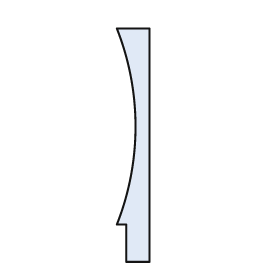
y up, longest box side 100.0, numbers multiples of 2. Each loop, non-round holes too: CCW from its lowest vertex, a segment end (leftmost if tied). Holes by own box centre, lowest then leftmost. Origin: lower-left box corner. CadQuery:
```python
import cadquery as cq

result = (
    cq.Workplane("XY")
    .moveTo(4.0, 0.0)
    .lineTo(14.0, 0.0)
    .lineTo(14.0, 100.0)
    .lineTo(0.0, 100.0)
    .threePointArc((8.0, 58.0), (0.0, 16.0))
    .lineTo(4.0, 16.0)
    .close()
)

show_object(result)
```